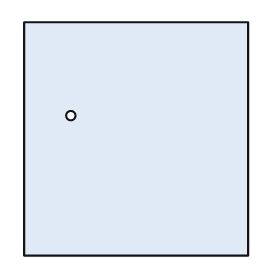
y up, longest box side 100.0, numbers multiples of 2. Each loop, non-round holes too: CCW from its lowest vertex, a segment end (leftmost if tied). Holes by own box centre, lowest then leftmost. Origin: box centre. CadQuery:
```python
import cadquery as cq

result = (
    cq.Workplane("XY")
    .moveTo(-48.0, -50.0)
    .lineTo(48.0, -50.0)
    .lineTo(48.0, 50.0)
    .lineTo(-48.0, 50.0)
    .close()
    .moveTo(-28.0, 10.0)
    .circle(2.0)
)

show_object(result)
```